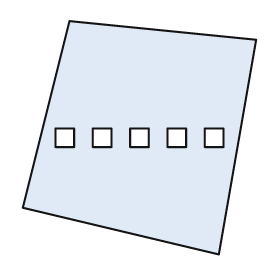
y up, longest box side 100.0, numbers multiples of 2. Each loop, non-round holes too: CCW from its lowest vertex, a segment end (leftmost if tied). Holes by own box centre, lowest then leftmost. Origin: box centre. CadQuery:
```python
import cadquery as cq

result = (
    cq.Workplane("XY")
    .moveTo(34.0, -50.0)
    .lineTo(50.0, 42.0)
    .lineTo(-30.0, 50.0)
    .lineTo(-50.0, -30.0)
    .close()
    .moveTo(-36.0, -4.0)
    .lineTo(-28.0, -4.0)
    .lineTo(-28.0, 4.0)
    .lineTo(-36.0, 4.0)
    .close()
    .moveTo(-20.0, -4.0)
    .lineTo(-12.0, -4.0)
    .lineTo(-12.0, 4.0)
    .lineTo(-20.0, 4.0)
    .close()
    .moveTo(-4.0, -4.0)
    .lineTo(4.0, -4.0)
    .lineTo(4.0, 4.0)
    .lineTo(-4.0, 4.0)
    .close()
    .moveTo(12.0, -4.0)
    .lineTo(20.0, -4.0)
    .lineTo(20.0, 4.0)
    .lineTo(12.0, 4.0)
    .close()
    .moveTo(28.0, -4.0)
    .lineTo(36.0, -4.0)
    .lineTo(36.0, 4.0)
    .lineTo(28.0, 4.0)
    .close()
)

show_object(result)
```